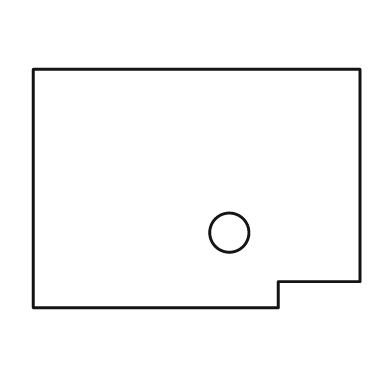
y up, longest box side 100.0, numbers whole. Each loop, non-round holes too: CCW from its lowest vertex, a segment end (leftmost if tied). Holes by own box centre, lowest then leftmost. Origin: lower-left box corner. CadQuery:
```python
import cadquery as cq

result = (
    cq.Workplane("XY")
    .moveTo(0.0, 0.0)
    .lineTo(75.0, 0.0)
    .lineTo(75.0, 8.0)
    .lineTo(100.0, 8.0)
    .lineTo(100.0, 73.0)
    .lineTo(0.0, 73.0)
    .close()
    .moveTo(60.0, 23.0)
    .circle(6.0)
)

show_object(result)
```